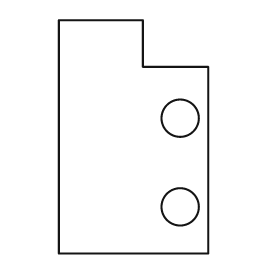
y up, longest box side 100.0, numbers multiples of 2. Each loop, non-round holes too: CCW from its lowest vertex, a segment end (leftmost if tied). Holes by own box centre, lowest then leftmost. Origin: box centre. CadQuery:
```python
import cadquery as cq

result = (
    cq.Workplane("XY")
    .moveTo(-32.0, -50.0)
    .lineTo(32.0, -50.0)
    .lineTo(32.0, 30.0)
    .lineTo(4.0, 30.0)
    .lineTo(4.0, 50.0)
    .lineTo(-32.0, 50.0)
    .close()
    .moveTo(20.0, -30.0)
    .circle(8.0)
    .moveTo(20.0, 8.0)
    .circle(8.0)
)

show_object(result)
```